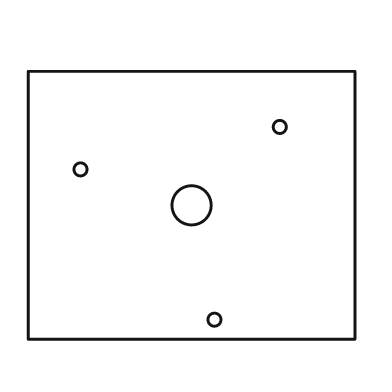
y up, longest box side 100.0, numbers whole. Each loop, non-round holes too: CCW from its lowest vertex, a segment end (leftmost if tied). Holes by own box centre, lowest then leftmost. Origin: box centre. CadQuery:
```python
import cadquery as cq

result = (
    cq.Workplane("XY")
    .moveTo(-50.0, -41.0)
    .lineTo(50.0, -41.0)
    .lineTo(50.0, 41.0)
    .lineTo(-50.0, 41.0)
    .close()
    .moveTo(7.0, -35.0)
    .circle(2.0)
    .moveTo(0.0, 0.0)
    .circle(6.0)
    .moveTo(-34.0, 11.0)
    .circle(2.0)
    .moveTo(27.0, 24.0)
    .circle(2.0)
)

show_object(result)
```